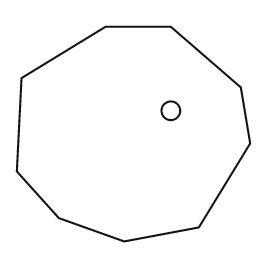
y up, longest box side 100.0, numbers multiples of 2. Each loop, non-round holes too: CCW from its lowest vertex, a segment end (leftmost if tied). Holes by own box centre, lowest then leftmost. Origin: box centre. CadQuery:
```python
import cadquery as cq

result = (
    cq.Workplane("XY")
    .moveTo(-4.0, -46.0)
    .lineTo(28.0, -40.0)
    .lineTo(50.0, -4.0)
    .lineTo(46.0, 20.0)
    .lineTo(16.0, 46.0)
    .lineTo(-12.0, 46.0)
    .lineTo(-48.0, 24.0)
    .lineTo(-50.0, -16.0)
    .lineTo(-32.0, -36.0)
    .close()
    .moveTo(16.0, 10.0)
    .circle(4.0)
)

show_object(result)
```